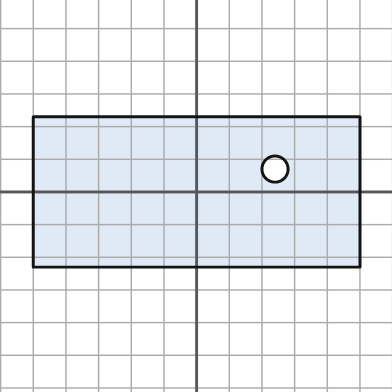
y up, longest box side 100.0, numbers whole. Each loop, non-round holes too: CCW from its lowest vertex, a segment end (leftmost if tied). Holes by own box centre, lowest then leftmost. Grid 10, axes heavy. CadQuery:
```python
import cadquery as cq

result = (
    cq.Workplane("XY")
    .moveTo(-50.0, -23.0)
    .lineTo(50.0, -23.0)
    .lineTo(50.0, 23.0)
    .lineTo(-50.0, 23.0)
    .close()
    .moveTo(24.0, 7.0)
    .circle(4.0)
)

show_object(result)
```